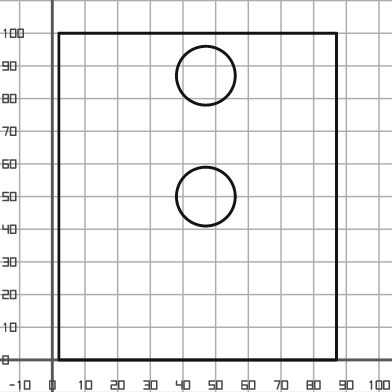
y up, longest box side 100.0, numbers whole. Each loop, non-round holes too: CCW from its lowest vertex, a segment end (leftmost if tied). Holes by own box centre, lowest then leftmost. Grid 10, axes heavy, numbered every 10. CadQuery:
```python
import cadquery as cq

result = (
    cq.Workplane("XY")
    .moveTo(2.0, 0.0)
    .lineTo(87.0, 0.0)
    .lineTo(87.0, 100.0)
    .lineTo(2.0, 100.0)
    .close()
    .moveTo(47.0, 50.0)
    .circle(9.0)
    .moveTo(47.0, 87.0)
    .circle(9.0)
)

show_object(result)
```